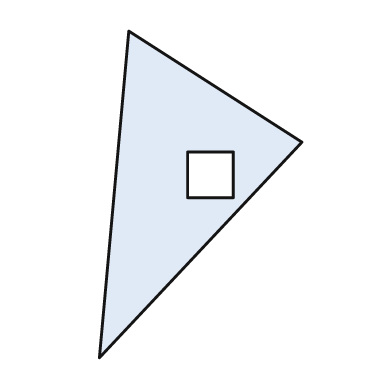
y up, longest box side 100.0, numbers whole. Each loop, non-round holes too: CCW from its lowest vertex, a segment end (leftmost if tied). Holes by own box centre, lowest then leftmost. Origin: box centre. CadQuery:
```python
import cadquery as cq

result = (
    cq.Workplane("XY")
    .moveTo(-31.0, -50.0)
    .lineTo(31.0, 16.0)
    .lineTo(-22.0, 50.0)
    .close()
    .moveTo(-4.0, -1.0)
    .lineTo(10.0, -1.0)
    .lineTo(10.0, 13.0)
    .lineTo(-4.0, 13.0)
    .close()
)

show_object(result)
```